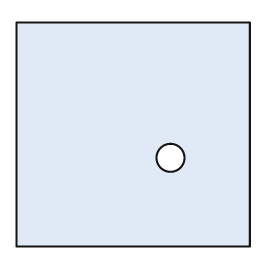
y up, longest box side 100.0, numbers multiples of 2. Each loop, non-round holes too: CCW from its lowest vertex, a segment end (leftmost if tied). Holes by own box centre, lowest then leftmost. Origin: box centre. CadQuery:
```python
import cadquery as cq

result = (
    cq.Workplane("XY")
    .moveTo(-50.0, -48.0)
    .lineTo(50.0, -48.0)
    .lineTo(50.0, 48.0)
    .lineTo(-50.0, 48.0)
    .close()
    .moveTo(16.0, -10.0)
    .circle(6.0)
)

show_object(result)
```